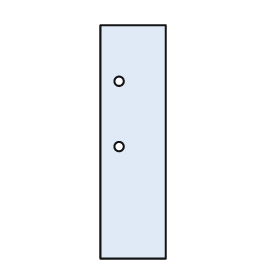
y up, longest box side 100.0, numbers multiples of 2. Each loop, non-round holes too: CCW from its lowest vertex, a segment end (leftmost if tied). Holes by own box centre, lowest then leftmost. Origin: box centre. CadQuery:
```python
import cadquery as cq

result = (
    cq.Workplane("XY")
    .moveTo(-14.0, -50.0)
    .lineTo(14.0, -50.0)
    .lineTo(14.0, 50.0)
    .lineTo(-14.0, 50.0)
    .close()
    .moveTo(-6.0, -2.0)
    .circle(2.0)
    .moveTo(-6.0, 26.0)
    .circle(2.0)
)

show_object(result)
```